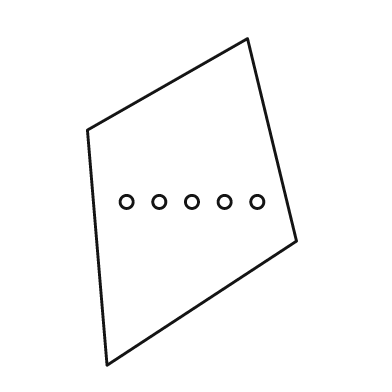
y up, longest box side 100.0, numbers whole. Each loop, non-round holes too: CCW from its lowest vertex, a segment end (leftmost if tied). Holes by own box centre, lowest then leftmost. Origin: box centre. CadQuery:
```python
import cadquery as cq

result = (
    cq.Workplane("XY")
    .moveTo(-26.0, -50.0)
    .lineTo(32.0, -12.0)
    .lineTo(17.0, 50.0)
    .lineTo(-32.0, 22.0)
    .close()
    .moveTo(-20.0, 0.0)
    .circle(2.0)
    .moveTo(-10.0, 0.0)
    .circle(2.0)
    .moveTo(0.0, 0.0)
    .circle(2.0)
    .moveTo(10.0, 0.0)
    .circle(2.0)
    .moveTo(20.0, 0.0)
    .circle(2.0)
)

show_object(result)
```